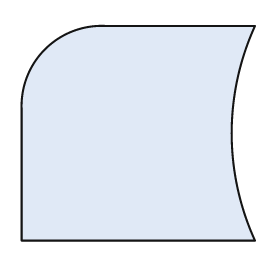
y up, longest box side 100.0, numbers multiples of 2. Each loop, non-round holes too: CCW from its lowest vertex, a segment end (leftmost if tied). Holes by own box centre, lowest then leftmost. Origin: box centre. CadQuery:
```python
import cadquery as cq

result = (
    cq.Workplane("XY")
    .moveTo(-50.0, -46.0)
    .lineTo(50.0, -46.0)
    .threePointArc((40.0, 0.0), (50.0, 46.0))
    .lineTo(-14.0, 46.0)
    .threePointArc((-40.0, 36.0), (-50.0, 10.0))
    .close()
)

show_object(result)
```